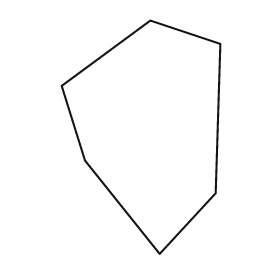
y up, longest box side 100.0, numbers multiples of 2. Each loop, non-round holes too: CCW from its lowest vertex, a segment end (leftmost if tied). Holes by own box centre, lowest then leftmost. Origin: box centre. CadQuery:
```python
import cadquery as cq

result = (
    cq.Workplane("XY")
    .moveTo(8.0, -50.0)
    .lineTo(32.0, -24.0)
    .lineTo(34.0, 40.0)
    .lineTo(4.0, 50.0)
    .lineTo(-34.0, 22.0)
    .lineTo(-24.0, -10.0)
    .close()
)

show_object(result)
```